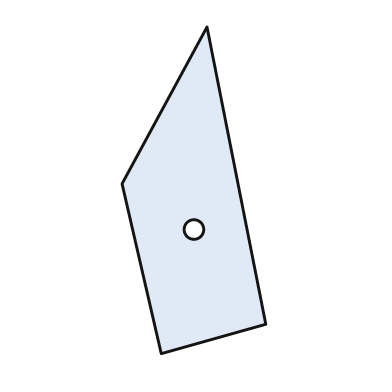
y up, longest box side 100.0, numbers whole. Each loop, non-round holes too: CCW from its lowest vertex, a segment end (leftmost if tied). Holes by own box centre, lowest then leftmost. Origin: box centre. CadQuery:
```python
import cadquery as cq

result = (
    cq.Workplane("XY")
    .moveTo(-10.0, -50.0)
    .lineTo(22.0, -41.0)
    .lineTo(4.0, 50.0)
    .lineTo(-22.0, 2.0)
    .close()
    .moveTo(0.0, -12.0)
    .circle(3.0)
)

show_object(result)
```